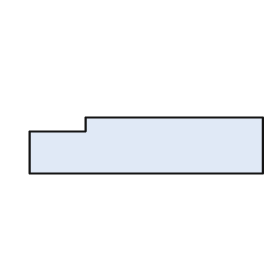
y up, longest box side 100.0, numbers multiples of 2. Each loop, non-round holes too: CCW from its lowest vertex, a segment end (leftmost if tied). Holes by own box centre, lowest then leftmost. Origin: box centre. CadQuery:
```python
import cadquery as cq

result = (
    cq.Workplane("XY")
    .moveTo(-50.0, -12.0)
    .lineTo(50.0, -12.0)
    .lineTo(50.0, 12.0)
    .lineTo(-26.0, 12.0)
    .lineTo(-26.0, 6.0)
    .lineTo(-50.0, 6.0)
    .close()
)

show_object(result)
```